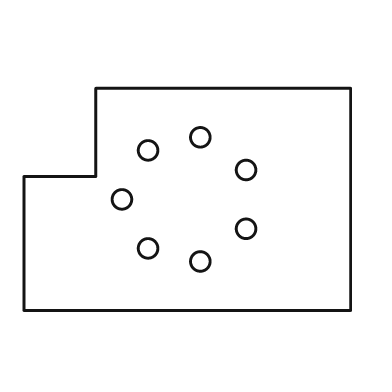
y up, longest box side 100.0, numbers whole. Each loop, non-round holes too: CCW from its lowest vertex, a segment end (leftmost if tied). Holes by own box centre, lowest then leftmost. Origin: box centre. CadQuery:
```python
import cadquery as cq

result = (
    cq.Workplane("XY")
    .moveTo(-50.0, -34.0)
    .lineTo(50.0, -34.0)
    .lineTo(50.0, 34.0)
    .lineTo(-28.0, 34.0)
    .lineTo(-28.0, 7.0)
    .lineTo(-50.0, 7.0)
    .close()
    .moveTo(4.0, -19.0)
    .circle(3.0)
    .moveTo(-12.0, -15.0)
    .circle(3.0)
    .moveTo(18.0, -9.0)
    .circle(3.0)
    .moveTo(-20.0, 0.0)
    .circle(3.0)
    .moveTo(18.0, 9.0)
    .circle(3.0)
    .moveTo(-12.0, 15.0)
    .circle(3.0)
    .moveTo(4.0, 19.0)
    .circle(3.0)
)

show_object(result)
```